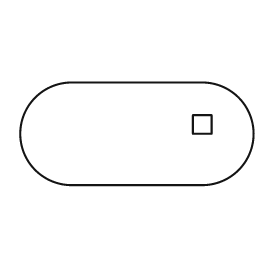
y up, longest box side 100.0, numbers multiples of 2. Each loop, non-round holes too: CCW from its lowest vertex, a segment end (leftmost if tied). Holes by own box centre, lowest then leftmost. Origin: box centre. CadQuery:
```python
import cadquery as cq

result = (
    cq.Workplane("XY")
    .moveTo(-28.0, -22.0)
    .lineTo(28.0, -22.0)
    .threePointArc((50.0, 0.0), (28.0, 22.0))
    .lineTo(-28.0, 22.0)
    .threePointArc((-50.0, 0.0), (-28.0, -22.0))
    .close()
    .moveTo(24.0, 0.0)
    .lineTo(32.0, 0.0)
    .lineTo(32.0, 8.0)
    .lineTo(24.0, 8.0)
    .close()
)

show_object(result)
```